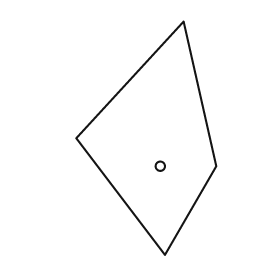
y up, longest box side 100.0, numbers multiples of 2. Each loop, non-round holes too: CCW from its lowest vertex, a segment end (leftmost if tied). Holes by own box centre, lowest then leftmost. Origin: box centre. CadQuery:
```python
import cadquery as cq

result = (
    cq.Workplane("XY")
    .moveTo(8.0, -50.0)
    .lineTo(30.0, -12.0)
    .lineTo(16.0, 50.0)
    .lineTo(-30.0, 0.0)
    .close()
    .moveTo(6.0, -12.0)
    .circle(2.0)
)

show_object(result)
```